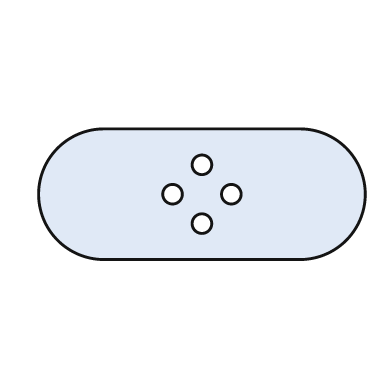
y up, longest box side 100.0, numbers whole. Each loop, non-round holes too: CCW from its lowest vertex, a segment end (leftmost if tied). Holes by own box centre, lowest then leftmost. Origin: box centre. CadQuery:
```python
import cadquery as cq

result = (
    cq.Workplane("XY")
    .moveTo(-30.0, -20.0)
    .lineTo(30.0, -20.0)
    .threePointArc((50.0, 0.0), (30.0, 20.0))
    .lineTo(-30.0, 20.0)
    .threePointArc((-50.0, 0.0), (-30.0, -20.0))
    .close()
    .moveTo(0.0, -9.0)
    .circle(3.0)
    .moveTo(-9.0, 0.0)
    .circle(3.0)
    .moveTo(9.0, 0.0)
    .circle(3.0)
    .moveTo(0.0, 9.0)
    .circle(3.0)
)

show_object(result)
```